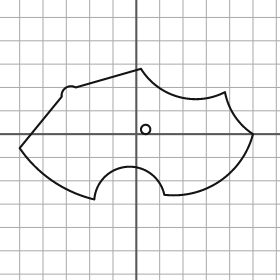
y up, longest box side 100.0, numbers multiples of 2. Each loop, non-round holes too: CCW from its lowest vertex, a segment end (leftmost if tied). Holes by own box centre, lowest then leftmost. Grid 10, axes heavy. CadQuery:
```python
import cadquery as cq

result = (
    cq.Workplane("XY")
    .moveTo(-18.0, -28.0)
    .threePointArc((-4.0, -14.0), (12.0, -26.0))
    .threePointArc((36.0, -20.0), (50.0, 0.0))
    .threePointArc((42.0, 8.0), (38.0, 18.0))
    .threePointArc((18.0, 16.0), (2.0, 28.0))
    .lineTo(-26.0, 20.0)
    .threePointArc((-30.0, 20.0), (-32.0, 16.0))
    .lineTo(-50.0, -6.0)
    .threePointArc((-36.0, -20.0), (-18.0, -28.0))
    .close()
    .moveTo(4.0, 2.0)
    .circle(2.0)
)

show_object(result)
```